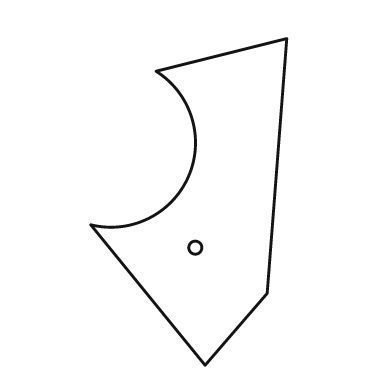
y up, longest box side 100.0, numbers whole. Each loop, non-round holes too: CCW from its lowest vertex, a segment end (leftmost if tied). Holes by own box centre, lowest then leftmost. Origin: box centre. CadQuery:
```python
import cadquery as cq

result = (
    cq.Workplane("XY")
    .moveTo(5.0, -50.0)
    .lineTo(24.0, -28.0)
    .lineTo(30.0, 50.0)
    .lineTo(-10.0, 40.0)
    .threePointArc((0.0, 8.0), (-30.0, -7.0))
    .close()
    .moveTo(2.0, -14.0)
    .circle(2.0)
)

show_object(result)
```